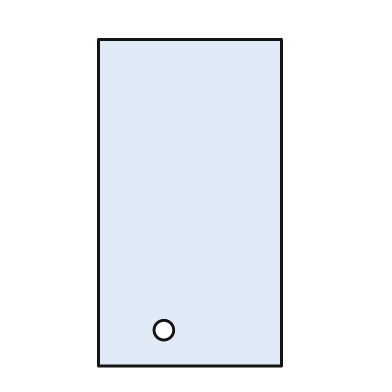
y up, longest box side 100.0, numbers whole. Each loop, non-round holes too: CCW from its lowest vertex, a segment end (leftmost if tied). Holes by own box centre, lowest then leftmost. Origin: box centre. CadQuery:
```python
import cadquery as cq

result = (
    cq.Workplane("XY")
    .moveTo(-28.0, -50.0)
    .lineTo(28.0, -50.0)
    .lineTo(28.0, 50.0)
    .lineTo(-28.0, 50.0)
    .close()
    .moveTo(-8.0, -39.0)
    .circle(3.0)
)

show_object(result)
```